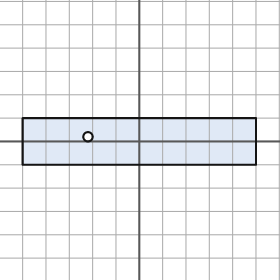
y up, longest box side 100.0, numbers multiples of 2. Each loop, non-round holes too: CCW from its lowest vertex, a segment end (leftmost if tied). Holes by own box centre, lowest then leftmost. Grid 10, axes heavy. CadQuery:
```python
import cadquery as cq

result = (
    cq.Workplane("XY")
    .moveTo(-50.0, -10.0)
    .lineTo(50.0, -10.0)
    .lineTo(50.0, 10.0)
    .lineTo(-50.0, 10.0)
    .close()
    .moveTo(-22.0, 2.0)
    .circle(2.0)
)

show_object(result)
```